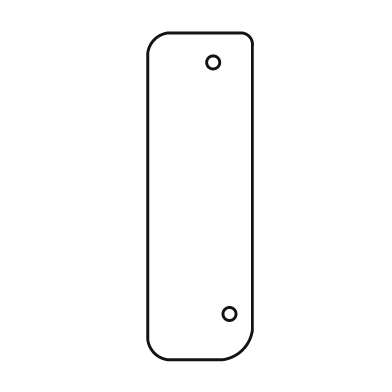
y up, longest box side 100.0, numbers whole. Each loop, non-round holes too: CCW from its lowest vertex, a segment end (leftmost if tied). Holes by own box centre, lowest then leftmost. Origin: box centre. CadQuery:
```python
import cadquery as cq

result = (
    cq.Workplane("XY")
    .moveTo(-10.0, -50.0)
    .lineTo(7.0, -50.0)
    .threePointArc((13.0, -47.0), (16.0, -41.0))
    .lineTo(16.0, 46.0)
    .threePointArc((15.0, 49.0), (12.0, 50.0))
    .lineTo(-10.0, 50.0)
    .threePointArc((-14.0, 48.0), (-16.0, 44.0))
    .lineTo(-16.0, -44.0)
    .threePointArc((-14.0, -48.0), (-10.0, -50.0))
    .close()
    .moveTo(9.0, -36.0)
    .circle(2.0)
    .moveTo(4.0, 41.0)
    .circle(2.0)
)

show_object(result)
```